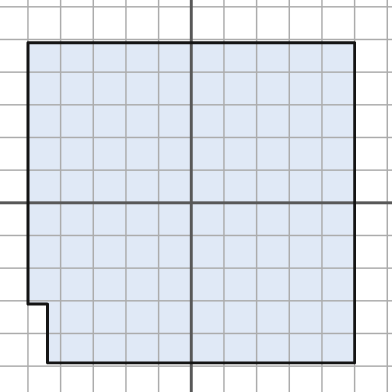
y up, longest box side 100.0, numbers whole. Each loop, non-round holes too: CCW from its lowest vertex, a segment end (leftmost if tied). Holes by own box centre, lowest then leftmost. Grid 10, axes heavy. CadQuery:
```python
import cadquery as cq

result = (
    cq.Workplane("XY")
    .moveTo(-44.0, -49.0)
    .lineTo(50.0, -49.0)
    .lineTo(50.0, 49.0)
    .lineTo(-50.0, 49.0)
    .lineTo(-50.0, -31.0)
    .lineTo(-44.0, -31.0)
    .close()
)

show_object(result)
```